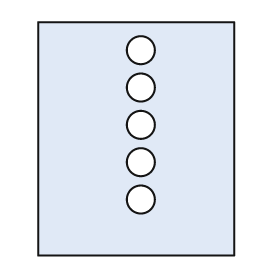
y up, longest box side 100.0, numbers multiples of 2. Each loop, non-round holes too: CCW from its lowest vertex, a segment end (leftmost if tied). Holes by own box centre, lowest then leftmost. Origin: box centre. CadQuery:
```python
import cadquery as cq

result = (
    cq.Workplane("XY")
    .moveTo(-42.0, -50.0)
    .lineTo(42.0, -50.0)
    .lineTo(42.0, 50.0)
    .lineTo(-42.0, 50.0)
    .close()
    .moveTo(2.0, -26.0)
    .circle(6.0)
    .moveTo(2.0, -10.0)
    .circle(6.0)
    .moveTo(2.0, 6.0)
    .circle(6.0)
    .moveTo(2.0, 22.0)
    .circle(6.0)
    .moveTo(2.0, 38.0)
    .circle(6.0)
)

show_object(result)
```